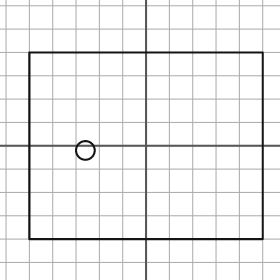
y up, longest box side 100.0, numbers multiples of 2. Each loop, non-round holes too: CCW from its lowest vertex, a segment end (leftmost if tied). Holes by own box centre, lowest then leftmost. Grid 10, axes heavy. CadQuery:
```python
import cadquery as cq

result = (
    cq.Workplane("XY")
    .moveTo(-50.0, -40.0)
    .lineTo(50.0, -40.0)
    .lineTo(50.0, 40.0)
    .lineTo(-50.0, 40.0)
    .close()
    .moveTo(-26.0, -2.0)
    .circle(4.0)
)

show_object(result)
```